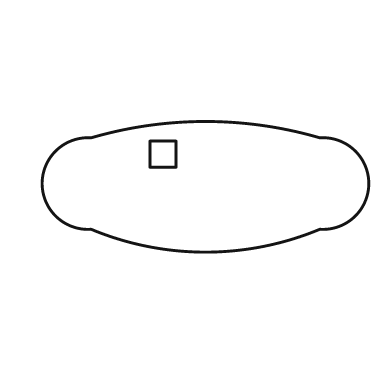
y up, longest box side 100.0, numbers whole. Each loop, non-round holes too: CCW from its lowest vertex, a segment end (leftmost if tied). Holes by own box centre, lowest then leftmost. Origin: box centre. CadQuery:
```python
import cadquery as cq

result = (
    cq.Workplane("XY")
    .moveTo(-35.0, -13.0)
    .threePointArc((0.0, -20.0), (35.0, -13.0))
    .threePointArc((50.0, 1.0), (35.0, 15.0))
    .threePointArc((0.0, 20.0), (-35.0, 15.0))
    .threePointArc((-50.0, 1.0), (-35.0, -13.0))
    .close()
    .moveTo(-17.0, 6.0)
    .lineTo(-9.0, 6.0)
    .lineTo(-9.0, 14.0)
    .lineTo(-17.0, 14.0)
    .close()
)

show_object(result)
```